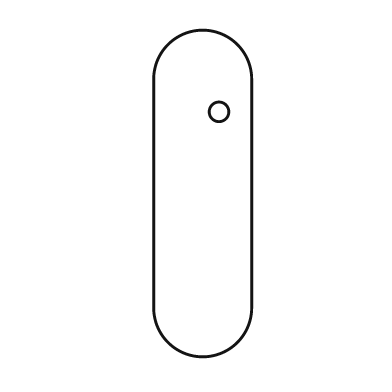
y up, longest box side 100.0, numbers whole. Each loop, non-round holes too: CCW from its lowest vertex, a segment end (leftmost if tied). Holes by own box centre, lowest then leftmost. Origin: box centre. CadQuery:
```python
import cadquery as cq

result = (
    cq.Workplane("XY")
    .moveTo(-15.0, -35.0)
    .threePointArc((0.0, -50.0), (15.0, -35.0))
    .lineTo(15.0, 35.0)
    .threePointArc((0.0, 50.0), (-15.0, 35.0))
    .close()
    .moveTo(5.0, 25.0)
    .circle(3.0)
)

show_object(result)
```